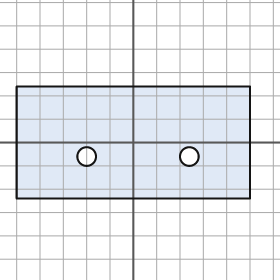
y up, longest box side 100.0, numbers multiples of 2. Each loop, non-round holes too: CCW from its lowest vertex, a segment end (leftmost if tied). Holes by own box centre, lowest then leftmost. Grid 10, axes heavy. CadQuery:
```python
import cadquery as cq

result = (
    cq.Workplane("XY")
    .moveTo(-50.0, -24.0)
    .lineTo(50.0, -24.0)
    .lineTo(50.0, 24.0)
    .lineTo(-50.0, 24.0)
    .close()
    .moveTo(-20.0, -6.0)
    .circle(4.0)
    .moveTo(24.0, -6.0)
    .circle(4.0)
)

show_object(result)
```